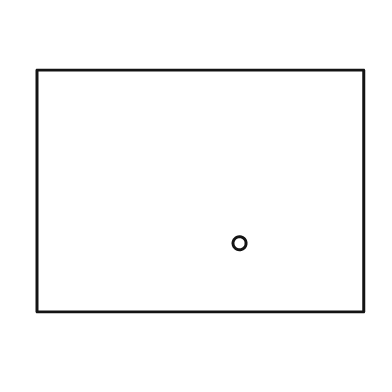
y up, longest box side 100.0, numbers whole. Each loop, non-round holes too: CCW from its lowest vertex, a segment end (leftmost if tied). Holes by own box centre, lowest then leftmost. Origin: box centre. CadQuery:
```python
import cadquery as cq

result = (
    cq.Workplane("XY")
    .moveTo(-50.0, -37.0)
    .lineTo(50.0, -37.0)
    .lineTo(50.0, 37.0)
    .lineTo(-50.0, 37.0)
    .close()
    .moveTo(12.0, -16.0)
    .circle(2.0)
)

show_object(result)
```